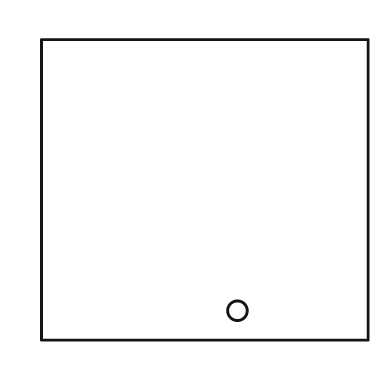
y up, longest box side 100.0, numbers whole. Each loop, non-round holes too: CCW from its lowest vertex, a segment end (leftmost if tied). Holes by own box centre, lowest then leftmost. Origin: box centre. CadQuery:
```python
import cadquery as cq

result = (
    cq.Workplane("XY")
    .moveTo(-50.0, -46.0)
    .lineTo(50.0, -46.0)
    .lineTo(50.0, 46.0)
    .lineTo(-50.0, 46.0)
    .close()
    .moveTo(10.0, -37.0)
    .circle(3.0)
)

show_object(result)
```